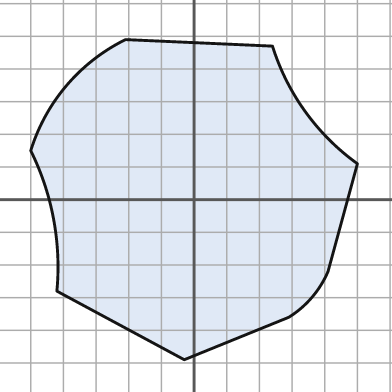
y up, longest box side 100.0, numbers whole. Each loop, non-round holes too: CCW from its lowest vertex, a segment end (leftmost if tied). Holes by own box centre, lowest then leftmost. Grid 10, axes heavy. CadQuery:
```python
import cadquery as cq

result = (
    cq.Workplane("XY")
    .moveTo(-3.0, -49.0)
    .lineTo(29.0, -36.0)
    .threePointArc((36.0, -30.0), (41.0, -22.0))
    .lineTo(50.0, 11.0)
    .threePointArc((34.0, 27.0), (24.0, 47.0))
    .lineTo(-21.0, 49.0)
    .threePointArc((-39.0, 35.0), (-50.0, 15.0))
    .threePointArc((-43.0, -6.0), (-42.0, -28.0))
    .close()
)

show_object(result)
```